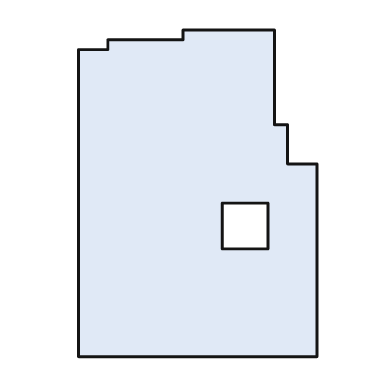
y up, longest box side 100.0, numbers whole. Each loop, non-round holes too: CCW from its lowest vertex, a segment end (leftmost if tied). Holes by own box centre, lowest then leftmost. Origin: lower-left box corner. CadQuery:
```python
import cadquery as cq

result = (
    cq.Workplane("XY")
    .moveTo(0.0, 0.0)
    .lineTo(73.0, 0.0)
    .lineTo(73.0, 59.0)
    .lineTo(64.0, 59.0)
    .lineTo(64.0, 71.0)
    .lineTo(60.0, 71.0)
    .lineTo(60.0, 100.0)
    .lineTo(32.0, 100.0)
    .lineTo(32.0, 97.0)
    .lineTo(9.0, 97.0)
    .lineTo(9.0, 94.0)
    .lineTo(0.0, 94.0)
    .close()
    .moveTo(44.0, 33.0)
    .lineTo(58.0, 33.0)
    .lineTo(58.0, 47.0)
    .lineTo(44.0, 47.0)
    .close()
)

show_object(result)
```